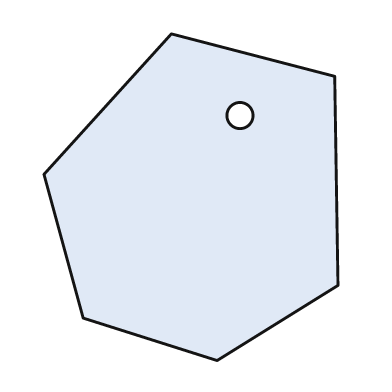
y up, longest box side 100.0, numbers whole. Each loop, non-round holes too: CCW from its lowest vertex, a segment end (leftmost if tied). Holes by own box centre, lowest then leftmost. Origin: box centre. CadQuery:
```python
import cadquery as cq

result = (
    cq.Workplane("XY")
    .moveTo(8.0, -50.0)
    .lineTo(45.0, -27.0)
    .lineTo(44.0, 37.0)
    .lineTo(-6.0, 50.0)
    .lineTo(-45.0, 7.0)
    .lineTo(-33.0, -37.0)
    .close()
    .moveTo(15.0, 25.0)
    .circle(4.0)
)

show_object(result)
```